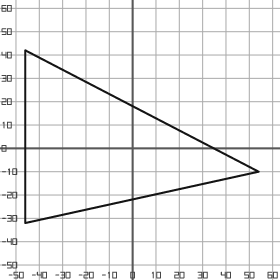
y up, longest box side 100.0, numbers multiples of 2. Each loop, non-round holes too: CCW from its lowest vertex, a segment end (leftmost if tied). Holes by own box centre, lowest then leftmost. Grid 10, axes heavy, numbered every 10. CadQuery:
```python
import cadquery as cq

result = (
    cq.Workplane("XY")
    .moveTo(-46.0, -32.0)
    .lineTo(54.0, -10.0)
    .lineTo(-46.0, 42.0)
    .close()
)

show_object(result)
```